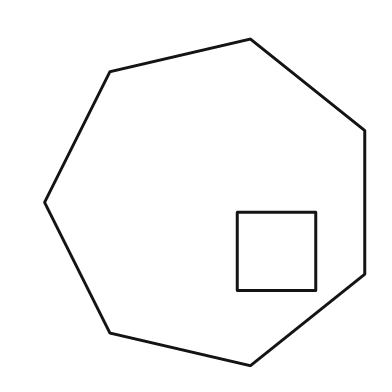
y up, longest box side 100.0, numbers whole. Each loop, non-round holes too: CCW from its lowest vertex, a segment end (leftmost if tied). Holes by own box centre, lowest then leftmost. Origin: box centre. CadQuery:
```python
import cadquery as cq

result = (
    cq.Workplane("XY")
    .moveTo(14.0, -50.0)
    .lineTo(49.0, -22.0)
    .lineTo(49.0, 22.0)
    .lineTo(14.0, 50.0)
    .lineTo(-29.0, 40.0)
    .lineTo(-49.0, 0.0)
    .lineTo(-29.0, -40.0)
    .close()
    .moveTo(10.0, -27.0)
    .lineTo(34.0, -27.0)
    .lineTo(34.0, -3.0)
    .lineTo(10.0, -3.0)
    .close()
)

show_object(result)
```